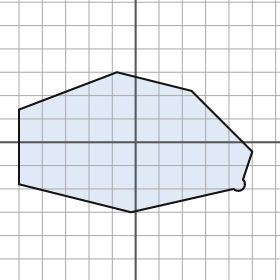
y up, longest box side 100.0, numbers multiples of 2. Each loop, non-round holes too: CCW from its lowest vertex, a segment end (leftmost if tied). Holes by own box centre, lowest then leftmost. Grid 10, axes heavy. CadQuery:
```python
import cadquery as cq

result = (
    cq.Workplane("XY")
    .moveTo(-2.0, -30.0)
    .lineTo(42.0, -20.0)
    .threePointArc((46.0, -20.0), (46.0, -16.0))
    .lineTo(50.0, -4.0)
    .lineTo(24.0, 22.0)
    .lineTo(-8.0, 30.0)
    .lineTo(-50.0, 14.0)
    .lineTo(-50.0, -18.0)
    .close()
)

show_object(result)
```